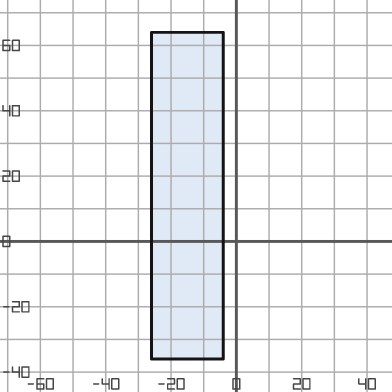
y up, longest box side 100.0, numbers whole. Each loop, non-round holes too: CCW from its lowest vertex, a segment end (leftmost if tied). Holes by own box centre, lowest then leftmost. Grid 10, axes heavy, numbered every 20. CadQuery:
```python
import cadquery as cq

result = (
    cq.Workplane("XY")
    .moveTo(-26.0, -36.0)
    .lineTo(-4.0, -36.0)
    .lineTo(-4.0, 64.0)
    .lineTo(-26.0, 64.0)
    .close()
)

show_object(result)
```